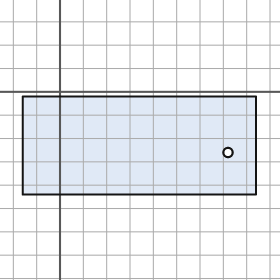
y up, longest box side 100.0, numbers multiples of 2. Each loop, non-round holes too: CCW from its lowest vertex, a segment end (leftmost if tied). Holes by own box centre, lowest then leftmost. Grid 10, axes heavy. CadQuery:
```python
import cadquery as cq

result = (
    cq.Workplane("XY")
    .moveTo(-16.0, -44.0)
    .lineTo(84.0, -44.0)
    .lineTo(84.0, -2.0)
    .lineTo(-16.0, -2.0)
    .close()
    .moveTo(72.0, -26.0)
    .circle(2.0)
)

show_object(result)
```